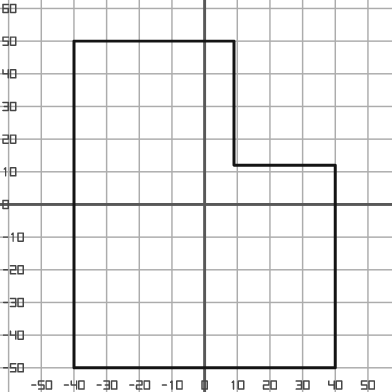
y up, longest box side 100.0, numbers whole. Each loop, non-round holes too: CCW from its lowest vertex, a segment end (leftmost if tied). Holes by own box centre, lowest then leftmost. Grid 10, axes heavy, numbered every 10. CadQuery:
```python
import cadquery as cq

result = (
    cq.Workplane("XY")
    .moveTo(-40.0, -50.0)
    .lineTo(40.0, -50.0)
    .lineTo(40.0, 12.0)
    .lineTo(9.0, 12.0)
    .lineTo(9.0, 50.0)
    .lineTo(-40.0, 50.0)
    .close()
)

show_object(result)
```